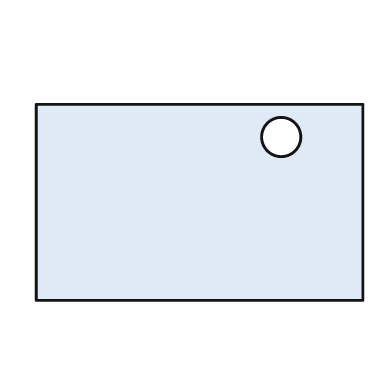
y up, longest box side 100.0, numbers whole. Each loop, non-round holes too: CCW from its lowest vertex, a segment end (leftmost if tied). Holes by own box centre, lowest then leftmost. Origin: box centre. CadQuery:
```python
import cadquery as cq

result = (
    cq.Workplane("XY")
    .moveTo(-50.0, -30.0)
    .lineTo(50.0, -30.0)
    .lineTo(50.0, 30.0)
    .lineTo(-50.0, 30.0)
    .close()
    .moveTo(25.0, 20.0)
    .circle(6.0)
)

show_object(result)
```